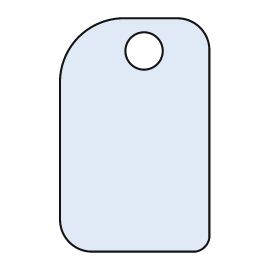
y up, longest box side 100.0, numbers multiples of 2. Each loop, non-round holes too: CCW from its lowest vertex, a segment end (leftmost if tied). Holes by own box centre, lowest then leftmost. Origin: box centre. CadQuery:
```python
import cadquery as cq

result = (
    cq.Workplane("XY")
    .moveTo(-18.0, -50.0)
    .lineTo(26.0, -50.0)
    .threePointArc((30.0, -48.0), (32.0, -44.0))
    .lineTo(32.0, 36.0)
    .threePointArc((28.0, 46.0), (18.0, 50.0))
    .lineTo(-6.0, 50.0)
    .threePointArc((-24.0, 42.0), (-32.0, 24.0))
    .lineTo(-32.0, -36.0)
    .threePointArc((-28.0, -46.0), (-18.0, -50.0))
    .close()
    .moveTo(4.0, 36.0)
    .circle(8.0)
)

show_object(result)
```